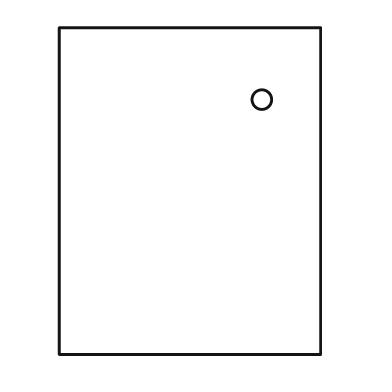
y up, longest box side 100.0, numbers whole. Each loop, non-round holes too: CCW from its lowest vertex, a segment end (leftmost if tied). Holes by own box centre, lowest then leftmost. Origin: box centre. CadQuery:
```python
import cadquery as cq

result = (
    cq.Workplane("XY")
    .moveTo(-40.0, -50.0)
    .lineTo(40.0, -50.0)
    .lineTo(40.0, 50.0)
    .lineTo(-40.0, 50.0)
    .close()
    .moveTo(22.0, 28.0)
    .circle(3.0)
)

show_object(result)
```